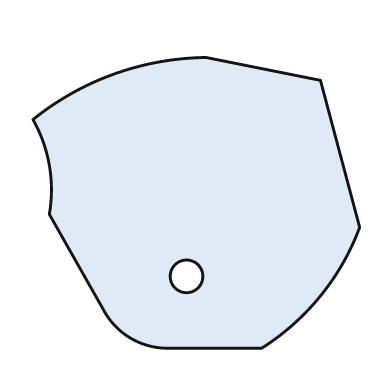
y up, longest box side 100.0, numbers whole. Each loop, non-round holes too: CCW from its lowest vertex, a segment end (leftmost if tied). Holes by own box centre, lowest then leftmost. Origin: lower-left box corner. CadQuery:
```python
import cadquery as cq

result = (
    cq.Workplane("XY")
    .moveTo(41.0, 0.0)
    .lineTo(70.0, 0.0)
    .threePointArc((88.0, 16.0), (100.0, 37.0))
    .lineTo(88.0, 82.0)
    .lineTo(53.0, 89.0)
    .threePointArc((25.0, 84.0), (0.0, 70.0))
    .threePointArc((5.0, 56.0), (5.0, 41.0))
    .lineTo(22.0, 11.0)
    .threePointArc((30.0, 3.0), (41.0, 0.0))
    .close()
    .moveTo(47.0, 22.0)
    .circle(5.0)
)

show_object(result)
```